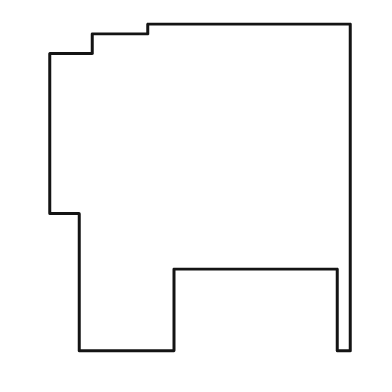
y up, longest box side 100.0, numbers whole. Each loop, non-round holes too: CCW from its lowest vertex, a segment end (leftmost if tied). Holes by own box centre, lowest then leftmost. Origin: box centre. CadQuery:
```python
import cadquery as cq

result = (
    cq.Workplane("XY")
    .moveTo(-37.0, -50.0)
    .lineTo(-8.0, -50.0)
    .lineTo(-8.0, -25.0)
    .lineTo(42.0, -25.0)
    .lineTo(42.0, -50.0)
    .lineTo(46.0, -50.0)
    .lineTo(46.0, 50.0)
    .lineTo(-16.0, 50.0)
    .lineTo(-16.0, 47.0)
    .lineTo(-33.0, 47.0)
    .lineTo(-33.0, 41.0)
    .lineTo(-46.0, 41.0)
    .lineTo(-46.0, -8.0)
    .lineTo(-37.0, -8.0)
    .close()
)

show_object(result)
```